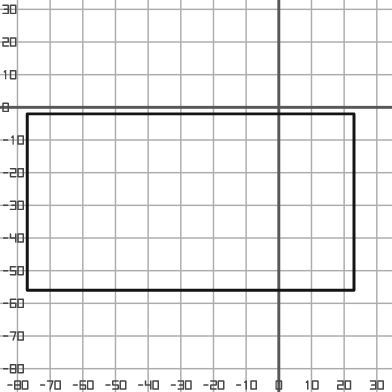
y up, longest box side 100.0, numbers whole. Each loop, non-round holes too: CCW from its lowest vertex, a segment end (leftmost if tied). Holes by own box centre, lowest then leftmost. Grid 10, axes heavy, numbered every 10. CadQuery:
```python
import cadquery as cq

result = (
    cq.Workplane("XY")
    .moveTo(-77.0, -56.0)
    .lineTo(23.0, -56.0)
    .lineTo(23.0, -2.0)
    .lineTo(-77.0, -2.0)
    .close()
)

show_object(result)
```